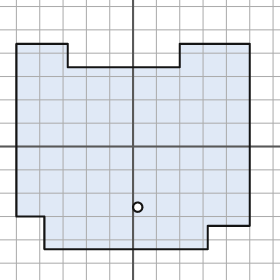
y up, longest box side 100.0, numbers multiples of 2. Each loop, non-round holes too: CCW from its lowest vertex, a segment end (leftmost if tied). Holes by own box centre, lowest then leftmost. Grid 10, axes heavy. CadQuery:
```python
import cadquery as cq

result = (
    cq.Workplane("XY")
    .moveTo(-38.0, -44.0)
    .lineTo(32.0, -44.0)
    .lineTo(32.0, -34.0)
    .lineTo(50.0, -34.0)
    .lineTo(50.0, 44.0)
    .lineTo(20.0, 44.0)
    .lineTo(20.0, 34.0)
    .lineTo(-28.0, 34.0)
    .lineTo(-28.0, 44.0)
    .lineTo(-50.0, 44.0)
    .lineTo(-50.0, -30.0)
    .lineTo(-38.0, -30.0)
    .close()
    .moveTo(2.0, -26.0)
    .circle(2.0)
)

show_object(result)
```